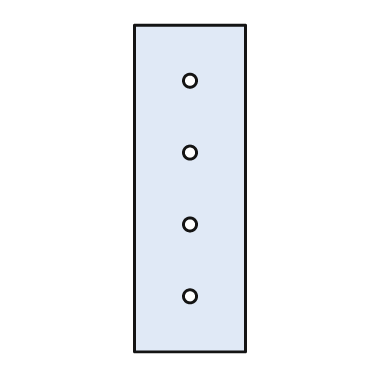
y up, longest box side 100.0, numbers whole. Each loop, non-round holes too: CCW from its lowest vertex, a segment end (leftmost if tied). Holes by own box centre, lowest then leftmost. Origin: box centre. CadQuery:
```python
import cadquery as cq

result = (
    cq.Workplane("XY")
    .moveTo(-17.0, -50.0)
    .lineTo(17.0, -50.0)
    .lineTo(17.0, 50.0)
    .lineTo(-17.0, 50.0)
    .close()
    .moveTo(0.0, -33.0)
    .circle(2.0)
    .moveTo(0.0, -11.0)
    .circle(2.0)
    .moveTo(0.0, 11.0)
    .circle(2.0)
    .moveTo(0.0, 33.0)
    .circle(2.0)
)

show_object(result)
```